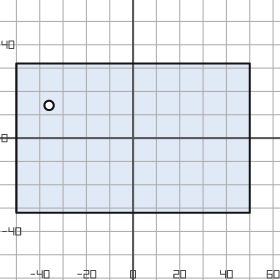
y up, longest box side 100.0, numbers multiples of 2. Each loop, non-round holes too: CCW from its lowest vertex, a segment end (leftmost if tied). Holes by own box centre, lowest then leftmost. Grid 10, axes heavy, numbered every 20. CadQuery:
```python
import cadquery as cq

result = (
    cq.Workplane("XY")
    .moveTo(-50.0, -32.0)
    .lineTo(50.0, -32.0)
    .lineTo(50.0, 32.0)
    .lineTo(-50.0, 32.0)
    .close()
    .moveTo(-36.0, 14.0)
    .circle(2.0)
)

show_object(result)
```